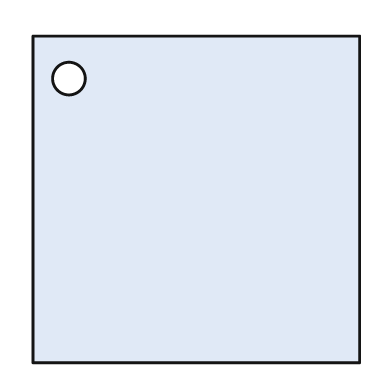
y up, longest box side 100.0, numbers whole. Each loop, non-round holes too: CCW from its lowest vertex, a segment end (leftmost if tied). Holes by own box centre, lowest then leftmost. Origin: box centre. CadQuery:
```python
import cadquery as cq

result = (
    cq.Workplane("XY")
    .moveTo(-50.0, -50.0)
    .lineTo(50.0, -50.0)
    .lineTo(50.0, 50.0)
    .lineTo(-50.0, 50.0)
    .close()
    .moveTo(-39.0, 37.0)
    .circle(5.0)
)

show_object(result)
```